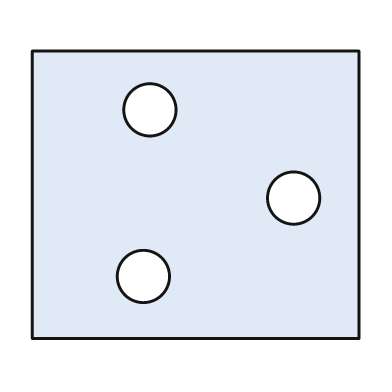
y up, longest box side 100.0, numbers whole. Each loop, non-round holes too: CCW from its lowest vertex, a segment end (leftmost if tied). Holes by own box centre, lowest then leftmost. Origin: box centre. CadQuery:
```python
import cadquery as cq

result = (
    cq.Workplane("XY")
    .moveTo(-50.0, -44.0)
    .lineTo(50.0, -44.0)
    .lineTo(50.0, 44.0)
    .lineTo(-50.0, 44.0)
    .close()
    .moveTo(-16.0, -25.0)
    .circle(8.0)
    .moveTo(30.0, -1.0)
    .circle(8.0)
    .moveTo(-14.0, 26.0)
    .circle(8.0)
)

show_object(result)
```